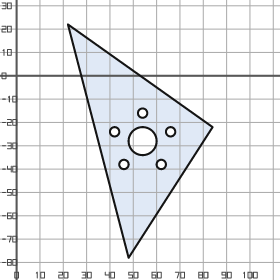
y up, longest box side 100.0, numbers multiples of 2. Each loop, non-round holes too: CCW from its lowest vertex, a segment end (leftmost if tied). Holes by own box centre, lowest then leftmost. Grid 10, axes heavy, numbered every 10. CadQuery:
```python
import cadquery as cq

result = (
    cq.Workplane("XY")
    .moveTo(48.0, -78.0)
    .lineTo(84.0, -22.0)
    .lineTo(22.0, 22.0)
    .close()
    .moveTo(46.0, -38.0)
    .circle(2.0)
    .moveTo(62.0, -38.0)
    .circle(2.0)
    .moveTo(54.0, -28.0)
    .circle(6.0)
    .moveTo(42.0, -24.0)
    .circle(2.0)
    .moveTo(66.0, -24.0)
    .circle(2.0)
    .moveTo(54.0, -16.0)
    .circle(2.0)
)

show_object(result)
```